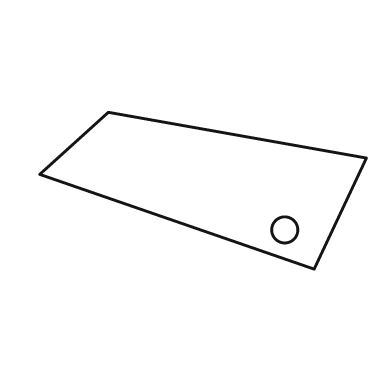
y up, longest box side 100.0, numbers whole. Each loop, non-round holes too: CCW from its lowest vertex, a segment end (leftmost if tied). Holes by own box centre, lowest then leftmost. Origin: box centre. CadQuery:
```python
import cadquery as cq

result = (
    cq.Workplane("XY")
    .moveTo(34.0, -24.0)
    .lineTo(50.0, 10.0)
    .lineTo(-29.0, 24.0)
    .lineTo(-50.0, 5.0)
    .close()
    .moveTo(25.0, -12.0)
    .circle(4.0)
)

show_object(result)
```